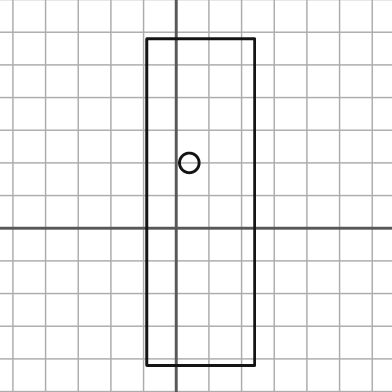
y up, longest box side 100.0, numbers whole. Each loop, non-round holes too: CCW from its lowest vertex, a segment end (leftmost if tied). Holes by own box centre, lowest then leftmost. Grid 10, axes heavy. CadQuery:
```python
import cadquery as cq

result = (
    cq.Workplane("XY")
    .moveTo(-9.0, -42.0)
    .lineTo(24.0, -42.0)
    .lineTo(24.0, 58.0)
    .lineTo(-9.0, 58.0)
    .close()
    .moveTo(4.0, 20.0)
    .circle(3.0)
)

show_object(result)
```